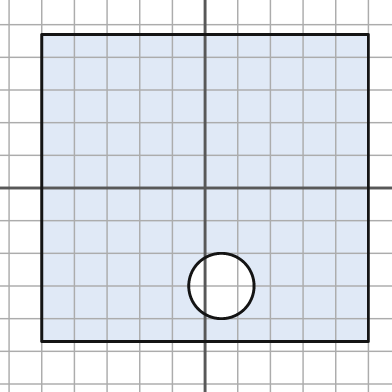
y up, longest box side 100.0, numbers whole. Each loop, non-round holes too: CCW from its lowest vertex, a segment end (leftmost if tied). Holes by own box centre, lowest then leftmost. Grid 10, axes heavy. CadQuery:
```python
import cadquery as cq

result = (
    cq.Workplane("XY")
    .moveTo(-50.0, -47.0)
    .lineTo(50.0, -47.0)
    .lineTo(50.0, 47.0)
    .lineTo(-50.0, 47.0)
    .close()
    .moveTo(5.0, -30.0)
    .circle(10.0)
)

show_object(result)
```